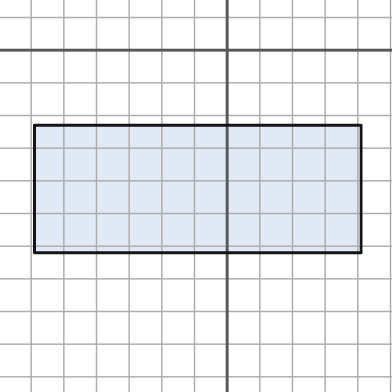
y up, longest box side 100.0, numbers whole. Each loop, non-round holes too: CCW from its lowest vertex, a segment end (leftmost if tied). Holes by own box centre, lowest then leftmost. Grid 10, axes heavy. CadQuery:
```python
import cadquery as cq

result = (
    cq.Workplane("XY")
    .moveTo(-59.0, -62.0)
    .lineTo(41.0, -62.0)
    .lineTo(41.0, -23.0)
    .lineTo(-59.0, -23.0)
    .close()
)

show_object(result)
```